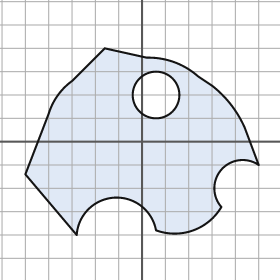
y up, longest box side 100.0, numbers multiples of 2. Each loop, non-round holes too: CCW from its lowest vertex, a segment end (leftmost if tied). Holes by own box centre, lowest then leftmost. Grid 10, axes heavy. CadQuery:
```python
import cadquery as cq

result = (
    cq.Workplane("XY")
    .moveTo(-28.0, -40.0)
    .threePointArc((-12.0, -24.0), (6.0, -38.0))
    .threePointArc((22.0, -38.0), (34.0, -28.0))
    .threePointArc((34.0, -12.0), (50.0, -10.0))
    .lineTo(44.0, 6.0)
    .threePointArc((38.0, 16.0), (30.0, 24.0))
    .lineTo(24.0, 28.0)
    .threePointArc((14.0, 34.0), (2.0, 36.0))
    .lineTo(-16.0, 40.0)
    .lineTo(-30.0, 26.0)
    .threePointArc((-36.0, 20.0), (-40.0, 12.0))
    .lineTo(-50.0, -14.0)
    .close()
    .moveTo(6.0, 20.0)
    .circle(10.0)
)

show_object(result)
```